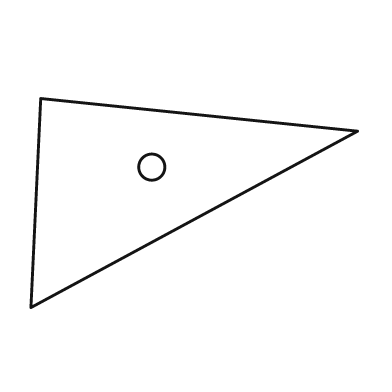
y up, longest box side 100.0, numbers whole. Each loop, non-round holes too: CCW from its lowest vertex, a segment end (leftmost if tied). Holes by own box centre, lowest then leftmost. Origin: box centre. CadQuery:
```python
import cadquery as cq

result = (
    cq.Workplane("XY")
    .moveTo(-50.0, -32.0)
    .lineTo(50.0, 22.0)
    .lineTo(-47.0, 32.0)
    .close()
    .moveTo(-13.0, 11.0)
    .circle(4.0)
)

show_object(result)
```